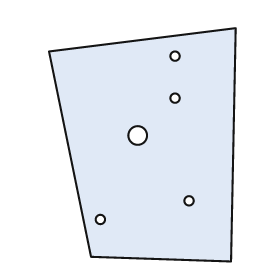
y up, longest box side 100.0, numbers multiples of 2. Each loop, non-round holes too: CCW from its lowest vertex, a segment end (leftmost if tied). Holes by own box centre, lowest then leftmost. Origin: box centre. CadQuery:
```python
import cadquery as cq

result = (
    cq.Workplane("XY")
    .moveTo(38.0, -50.0)
    .lineTo(40.0, 50.0)
    .lineTo(-40.0, 40.0)
    .lineTo(-22.0, -48.0)
    .close()
    .moveTo(-18.0, -32.0)
    .circle(2.0)
    .moveTo(20.0, -24.0)
    .circle(2.0)
    .moveTo(-2.0, 4.0)
    .circle(4.0)
    .moveTo(14.0, 20.0)
    .circle(2.0)
    .moveTo(14.0, 38.0)
    .circle(2.0)
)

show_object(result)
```